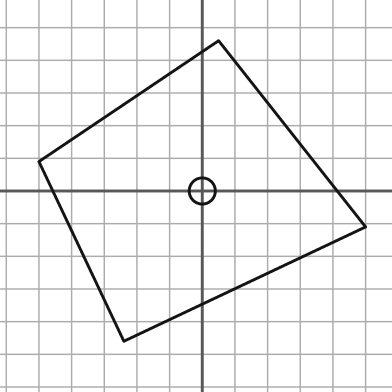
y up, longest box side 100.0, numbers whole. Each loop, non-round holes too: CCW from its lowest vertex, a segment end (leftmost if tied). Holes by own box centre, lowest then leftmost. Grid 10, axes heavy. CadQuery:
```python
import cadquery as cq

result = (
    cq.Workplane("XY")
    .moveTo(-24.0, -46.0)
    .lineTo(50.0, -11.0)
    .lineTo(5.0, 46.0)
    .lineTo(-50.0, 9.0)
    .close()
    .moveTo(0.0, 0.0)
    .circle(4.0)
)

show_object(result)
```